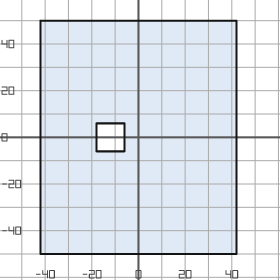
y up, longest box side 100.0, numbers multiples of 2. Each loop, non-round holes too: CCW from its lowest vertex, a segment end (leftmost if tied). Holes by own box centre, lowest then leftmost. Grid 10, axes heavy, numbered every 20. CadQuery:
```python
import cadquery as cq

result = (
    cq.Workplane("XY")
    .moveTo(-42.0, -50.0)
    .lineTo(42.0, -50.0)
    .lineTo(42.0, 50.0)
    .lineTo(-42.0, 50.0)
    .close()
    .moveTo(-18.0, -6.0)
    .lineTo(-6.0, -6.0)
    .lineTo(-6.0, 6.0)
    .lineTo(-18.0, 6.0)
    .close()
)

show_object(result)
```